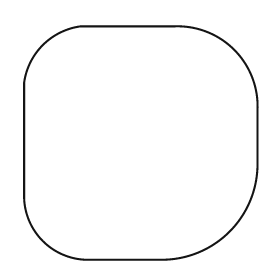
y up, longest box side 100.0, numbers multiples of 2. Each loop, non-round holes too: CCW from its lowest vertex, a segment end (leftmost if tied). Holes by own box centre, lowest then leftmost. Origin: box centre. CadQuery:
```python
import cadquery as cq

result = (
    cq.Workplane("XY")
    .moveTo(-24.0, -50.0)
    .lineTo(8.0, -50.0)
    .threePointArc((38.0, -38.0), (50.0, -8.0))
    .lineTo(50.0, 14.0)
    .threePointArc((40.0, 40.0), (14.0, 50.0))
    .lineTo(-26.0, 50.0)
    .threePointArc((-42.0, 42.0), (-50.0, 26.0))
    .lineTo(-50.0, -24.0)
    .threePointArc((-42.0, -42.0), (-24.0, -50.0))
    .close()
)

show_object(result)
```